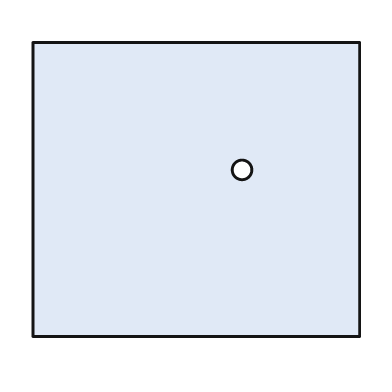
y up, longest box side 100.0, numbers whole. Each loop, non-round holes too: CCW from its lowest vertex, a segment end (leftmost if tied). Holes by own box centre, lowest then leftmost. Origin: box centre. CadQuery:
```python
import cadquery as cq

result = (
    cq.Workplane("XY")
    .moveTo(-50.0, -45.0)
    .lineTo(50.0, -45.0)
    .lineTo(50.0, 45.0)
    .lineTo(-50.0, 45.0)
    .close()
    .moveTo(14.0, 6.0)
    .circle(3.0)
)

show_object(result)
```